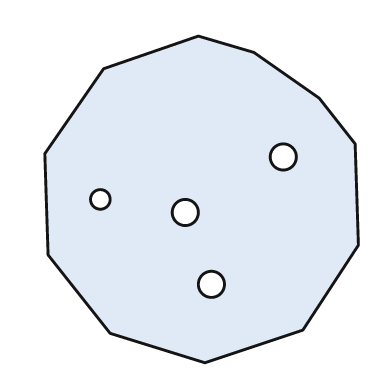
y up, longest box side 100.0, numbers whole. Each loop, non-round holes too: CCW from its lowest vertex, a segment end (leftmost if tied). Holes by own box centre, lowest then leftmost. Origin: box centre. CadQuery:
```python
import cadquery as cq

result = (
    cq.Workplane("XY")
    .moveTo(1.0, -50.0)
    .lineTo(31.0, -40.0)
    .lineTo(48.0, -14.0)
    .lineTo(47.0, 17.0)
    .lineTo(36.0, 31.0)
    .lineTo(16.0, 45.0)
    .lineTo(-1.0, 50.0)
    .lineTo(-30.0, 40.0)
    .lineTo(-48.0, 14.0)
    .lineTo(-47.0, -17.0)
    .lineTo(-28.0, -41.0)
    .close()
    .moveTo(3.0, -26.0)
    .circle(4.0)
    .moveTo(-5.0, -4.0)
    .circle(4.0)
    .moveTo(-31.0, 0.0)
    .circle(3.0)
    .moveTo(25.0, 13.0)
    .circle(4.0)
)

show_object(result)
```